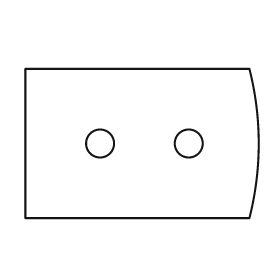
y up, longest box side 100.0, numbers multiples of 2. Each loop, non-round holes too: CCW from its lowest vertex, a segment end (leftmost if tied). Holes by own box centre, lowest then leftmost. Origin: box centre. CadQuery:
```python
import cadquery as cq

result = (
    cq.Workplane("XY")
    .moveTo(-50.0, -32.0)
    .lineTo(46.0, -32.0)
    .threePointArc((50.0, 0.0), (46.0, 32.0))
    .lineTo(-50.0, 32.0)
    .close()
    .moveTo(-18.0, 0.0)
    .circle(6.0)
    .moveTo(20.0, 0.0)
    .circle(6.0)
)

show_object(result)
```